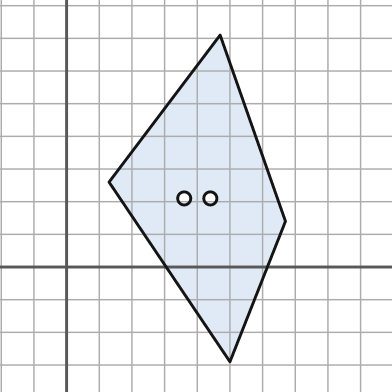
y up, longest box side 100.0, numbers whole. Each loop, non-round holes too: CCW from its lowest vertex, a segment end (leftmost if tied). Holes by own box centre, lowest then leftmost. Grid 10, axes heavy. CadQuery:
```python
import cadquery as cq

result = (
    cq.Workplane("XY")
    .moveTo(50.0, -29.0)
    .lineTo(67.0, 14.0)
    .lineTo(47.0, 71.0)
    .lineTo(13.0, 26.0)
    .close()
    .moveTo(36.0, 21.0)
    .circle(2.0)
    .moveTo(44.0, 21.0)
    .circle(2.0)
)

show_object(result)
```